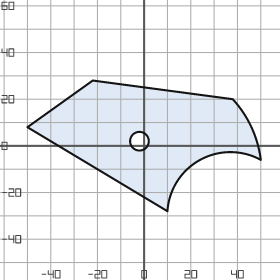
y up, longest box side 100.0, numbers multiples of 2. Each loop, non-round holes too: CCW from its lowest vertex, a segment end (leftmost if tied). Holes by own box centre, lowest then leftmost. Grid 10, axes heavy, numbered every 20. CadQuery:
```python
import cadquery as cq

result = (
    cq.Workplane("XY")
    .moveTo(10.0, -28.0)
    .threePointArc((24.0, -6.0), (50.0, -6.0))
    .threePointArc((46.0, 8.0), (38.0, 20.0))
    .lineTo(-22.0, 28.0)
    .lineTo(-50.0, 8.0)
    .close()
    .moveTo(-2.0, 2.0)
    .circle(4.0)
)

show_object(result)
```